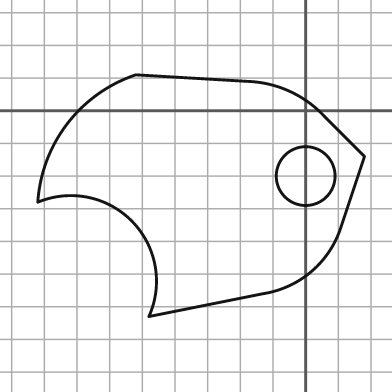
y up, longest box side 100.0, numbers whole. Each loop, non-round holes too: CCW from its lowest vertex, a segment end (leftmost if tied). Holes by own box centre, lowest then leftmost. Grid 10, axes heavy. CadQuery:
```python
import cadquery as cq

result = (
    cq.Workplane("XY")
    .moveTo(-48.0, -63.0)
    .lineTo(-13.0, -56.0)
    .threePointArc((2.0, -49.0), (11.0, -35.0))
    .lineTo(18.0, -14.0)
    .lineTo(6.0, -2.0)
    .threePointArc((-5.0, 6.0), (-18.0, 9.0))
    .lineTo(-52.0, 11.0)
    .threePointArc((-73.0, -4.0), (-82.0, -28.0))
    .threePointArc((-53.0, -34.0), (-48.0, -63.0))
    .close()
    .moveTo(0.0, -20.0)
    .circle(9.0)
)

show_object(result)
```